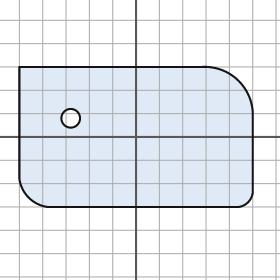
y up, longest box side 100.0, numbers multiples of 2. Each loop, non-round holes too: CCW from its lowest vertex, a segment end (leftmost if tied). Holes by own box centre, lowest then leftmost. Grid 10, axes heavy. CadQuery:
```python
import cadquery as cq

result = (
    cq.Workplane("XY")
    .moveTo(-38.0, -30.0)
    .lineTo(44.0, -30.0)
    .threePointArc((48.0, -28.0), (50.0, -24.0))
    .lineTo(50.0, 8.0)
    .threePointArc((44.0, 24.0), (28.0, 30.0))
    .lineTo(-50.0, 30.0)
    .lineTo(-50.0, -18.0)
    .threePointArc((-46.0, -26.0), (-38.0, -30.0))
    .close()
    .moveTo(-28.0, 8.0)
    .circle(4.0)
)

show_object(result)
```